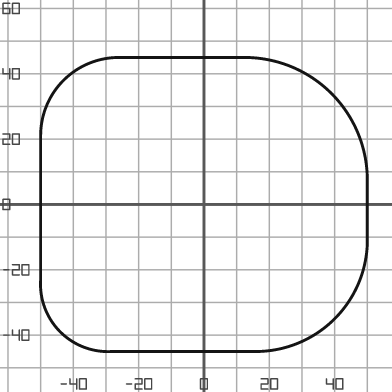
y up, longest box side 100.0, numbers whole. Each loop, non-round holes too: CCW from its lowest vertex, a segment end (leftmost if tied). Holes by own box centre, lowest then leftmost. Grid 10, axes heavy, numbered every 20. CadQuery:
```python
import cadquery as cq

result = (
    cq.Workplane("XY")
    .moveTo(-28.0, -45.0)
    .lineTo(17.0, -45.0)
    .threePointArc((40.0, -35.0), (50.0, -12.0))
    .lineTo(50.0, 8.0)
    .threePointArc((39.0, 34.0), (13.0, 45.0))
    .lineTo(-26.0, 45.0)
    .threePointArc((-43.0, 38.0), (-50.0, 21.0))
    .lineTo(-50.0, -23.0)
    .threePointArc((-44.0, -39.0), (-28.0, -45.0))
    .close()
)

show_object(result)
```